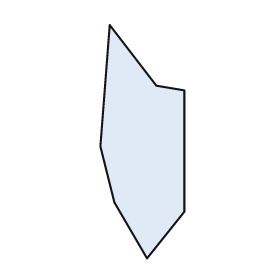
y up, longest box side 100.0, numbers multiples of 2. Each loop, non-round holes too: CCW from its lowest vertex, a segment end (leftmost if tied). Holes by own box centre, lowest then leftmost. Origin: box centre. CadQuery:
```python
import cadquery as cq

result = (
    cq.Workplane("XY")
    .moveTo(2.0, -50.0)
    .lineTo(18.0, -30.0)
    .lineTo(18.0, 22.0)
    .lineTo(6.0, 24.0)
    .lineTo(-14.0, 50.0)
    .lineTo(-18.0, -2.0)
    .lineTo(-12.0, -26.0)
    .close()
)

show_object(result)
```